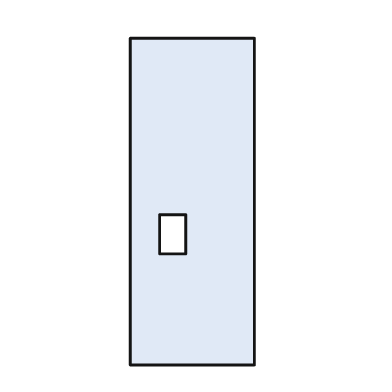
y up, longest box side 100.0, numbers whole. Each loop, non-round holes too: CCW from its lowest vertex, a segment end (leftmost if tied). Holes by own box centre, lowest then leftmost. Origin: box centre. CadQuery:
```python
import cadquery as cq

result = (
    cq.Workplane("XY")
    .moveTo(-19.0, -50.0)
    .lineTo(19.0, -50.0)
    .lineTo(19.0, 50.0)
    .lineTo(-19.0, 50.0)
    .close()
    .moveTo(-10.0, -16.0)
    .lineTo(-2.0, -16.0)
    .lineTo(-2.0, -4.0)
    .lineTo(-10.0, -4.0)
    .close()
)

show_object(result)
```